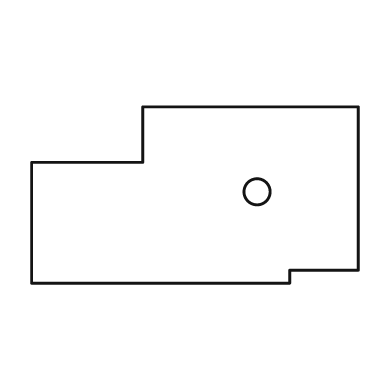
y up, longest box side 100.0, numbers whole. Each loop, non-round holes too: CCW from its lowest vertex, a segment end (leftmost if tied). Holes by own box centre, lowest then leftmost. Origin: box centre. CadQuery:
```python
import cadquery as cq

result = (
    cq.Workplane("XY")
    .moveTo(-50.0, -27.0)
    .lineTo(29.0, -27.0)
    .lineTo(29.0, -23.0)
    .lineTo(50.0, -23.0)
    .lineTo(50.0, 27.0)
    .lineTo(-16.0, 27.0)
    .lineTo(-16.0, 10.0)
    .lineTo(-50.0, 10.0)
    .close()
    .moveTo(19.0, 1.0)
    .circle(4.0)
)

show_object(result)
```